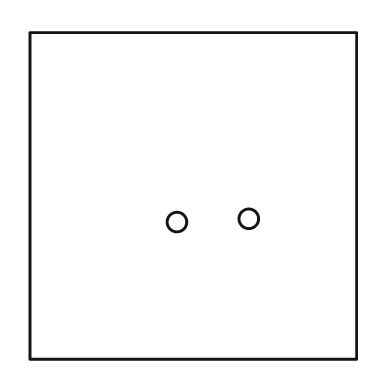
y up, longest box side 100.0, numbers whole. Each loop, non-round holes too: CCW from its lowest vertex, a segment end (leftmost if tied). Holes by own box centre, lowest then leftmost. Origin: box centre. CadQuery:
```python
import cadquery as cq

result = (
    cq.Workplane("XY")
    .moveTo(-50.0, -50.0)
    .lineTo(50.0, -50.0)
    .lineTo(50.0, 50.0)
    .lineTo(-50.0, 50.0)
    .close()
    .moveTo(-5.0, -8.0)
    .circle(3.0)
    .moveTo(17.0, -7.0)
    .circle(3.0)
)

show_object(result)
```